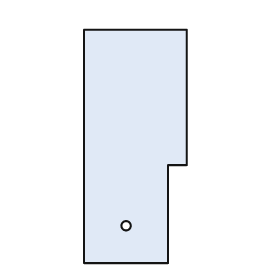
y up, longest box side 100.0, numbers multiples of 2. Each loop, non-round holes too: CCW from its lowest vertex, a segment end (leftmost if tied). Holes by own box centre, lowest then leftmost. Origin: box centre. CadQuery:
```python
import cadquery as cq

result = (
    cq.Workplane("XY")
    .moveTo(-22.0, -50.0)
    .lineTo(14.0, -50.0)
    .lineTo(14.0, -8.0)
    .lineTo(22.0, -8.0)
    .lineTo(22.0, 50.0)
    .lineTo(-22.0, 50.0)
    .close()
    .moveTo(-4.0, -34.0)
    .circle(2.0)
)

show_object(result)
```